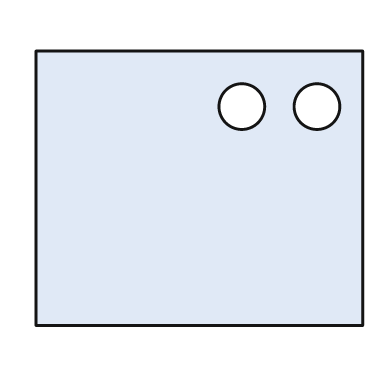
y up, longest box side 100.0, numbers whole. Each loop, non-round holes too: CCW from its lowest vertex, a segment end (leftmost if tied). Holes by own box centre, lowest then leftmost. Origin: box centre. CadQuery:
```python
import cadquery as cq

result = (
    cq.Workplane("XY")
    .moveTo(-50.0, -42.0)
    .lineTo(50.0, -42.0)
    .lineTo(50.0, 42.0)
    .lineTo(-50.0, 42.0)
    .close()
    .moveTo(13.0, 25.0)
    .circle(7.0)
    .moveTo(36.0, 25.0)
    .circle(7.0)
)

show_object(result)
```